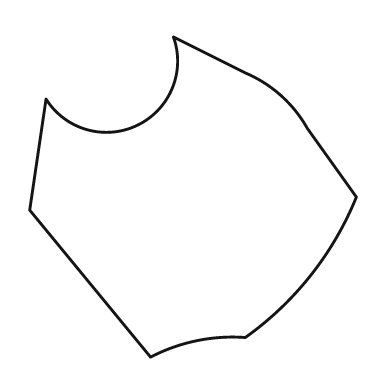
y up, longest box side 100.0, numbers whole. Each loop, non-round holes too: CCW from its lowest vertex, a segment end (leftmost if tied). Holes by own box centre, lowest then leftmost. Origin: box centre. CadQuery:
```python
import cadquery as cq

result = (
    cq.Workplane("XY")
    .moveTo(-13.0, -49.0)
    .threePointArc((1.0, -44.0), (16.0, -43.0))
    .threePointArc((36.0, -24.0), (50.0, 0.0))
    .lineTo(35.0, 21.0)
    .threePointArc((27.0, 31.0), (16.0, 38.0))
    .lineTo(-6.0, 49.0)
    .threePointArc((-17.0, 22.0), (-45.0, 30.0))
    .lineTo(-50.0, -4.0)
    .close()
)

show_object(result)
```